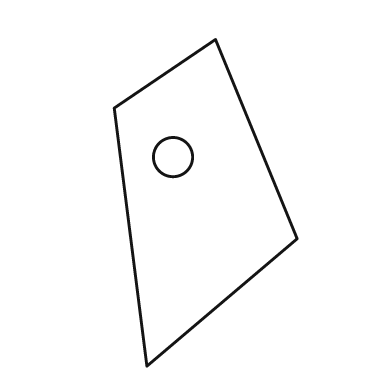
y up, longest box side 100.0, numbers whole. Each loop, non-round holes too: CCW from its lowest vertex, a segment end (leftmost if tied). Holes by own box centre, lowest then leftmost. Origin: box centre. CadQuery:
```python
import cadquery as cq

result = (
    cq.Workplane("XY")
    .moveTo(-18.0, -50.0)
    .lineTo(28.0, -11.0)
    .lineTo(3.0, 50.0)
    .lineTo(-28.0, 29.0)
    .close()
    .moveTo(-10.0, 14.0)
    .circle(6.0)
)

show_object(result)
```